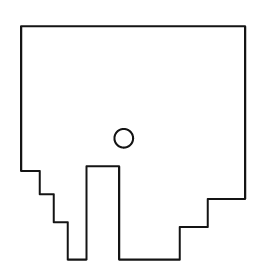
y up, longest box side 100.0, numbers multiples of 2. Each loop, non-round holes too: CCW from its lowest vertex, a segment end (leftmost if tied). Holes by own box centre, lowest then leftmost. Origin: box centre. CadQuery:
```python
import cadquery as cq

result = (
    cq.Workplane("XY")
    .moveTo(-28.0, -50.0)
    .lineTo(-20.0, -50.0)
    .lineTo(-20.0, -10.0)
    .lineTo(-6.0, -10.0)
    .lineTo(-6.0, -50.0)
    .lineTo(20.0, -50.0)
    .lineTo(20.0, -36.0)
    .lineTo(32.0, -36.0)
    .lineTo(32.0, -24.0)
    .lineTo(48.0, -24.0)
    .lineTo(48.0, 50.0)
    .lineTo(-48.0, 50.0)
    .lineTo(-48.0, -12.0)
    .lineTo(-40.0, -12.0)
    .lineTo(-40.0, -22.0)
    .lineTo(-34.0, -22.0)
    .lineTo(-34.0, -34.0)
    .lineTo(-28.0, -34.0)
    .close()
    .moveTo(-4.0, 2.0)
    .circle(4.0)
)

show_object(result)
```